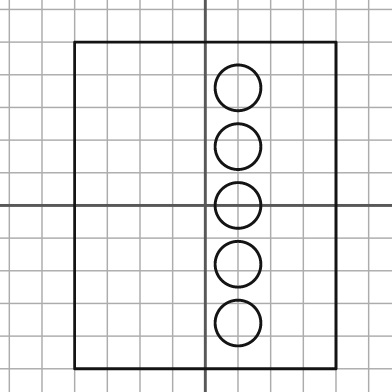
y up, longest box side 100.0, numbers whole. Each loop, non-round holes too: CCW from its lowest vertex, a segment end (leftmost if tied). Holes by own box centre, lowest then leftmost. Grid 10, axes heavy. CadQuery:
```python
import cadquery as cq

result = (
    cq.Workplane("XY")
    .moveTo(-40.0, -50.0)
    .lineTo(40.0, -50.0)
    .lineTo(40.0, 50.0)
    .lineTo(-40.0, 50.0)
    .close()
    .moveTo(10.0, -36.0)
    .circle(7.0)
    .moveTo(10.0, -18.0)
    .circle(7.0)
    .moveTo(10.0, 0.0)
    .circle(7.0)
    .moveTo(10.0, 18.0)
    .circle(7.0)
    .moveTo(10.0, 36.0)
    .circle(7.0)
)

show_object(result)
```